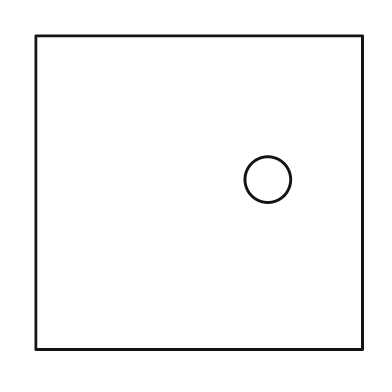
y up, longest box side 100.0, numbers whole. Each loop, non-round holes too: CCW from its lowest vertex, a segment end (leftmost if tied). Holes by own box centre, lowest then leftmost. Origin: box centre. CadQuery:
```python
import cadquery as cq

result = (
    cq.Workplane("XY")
    .moveTo(-50.0, -48.0)
    .lineTo(50.0, -48.0)
    .lineTo(50.0, 48.0)
    .lineTo(-50.0, 48.0)
    .close()
    .moveTo(21.0, 4.0)
    .circle(7.0)
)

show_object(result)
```